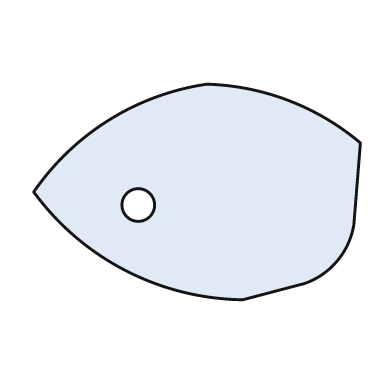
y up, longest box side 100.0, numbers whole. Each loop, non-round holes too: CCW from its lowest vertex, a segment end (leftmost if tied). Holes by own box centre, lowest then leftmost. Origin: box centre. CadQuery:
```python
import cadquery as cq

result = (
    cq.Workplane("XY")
    .moveTo(14.0, -33.0)
    .lineTo(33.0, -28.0)
    .threePointArc((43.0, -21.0), (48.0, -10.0))
    .lineTo(50.0, 15.0)
    .threePointArc((28.0, 28.0), (3.0, 33.0))
    .threePointArc((-27.0, 22.0), (-50.0, 0.0))
    .threePointArc((-22.0, -24.0), (14.0, -33.0))
    .close()
    .moveTo(-18.0, -4.0)
    .circle(5.0)
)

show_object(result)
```